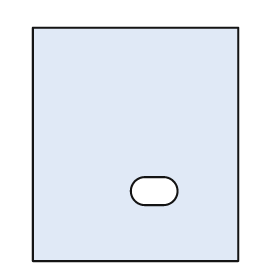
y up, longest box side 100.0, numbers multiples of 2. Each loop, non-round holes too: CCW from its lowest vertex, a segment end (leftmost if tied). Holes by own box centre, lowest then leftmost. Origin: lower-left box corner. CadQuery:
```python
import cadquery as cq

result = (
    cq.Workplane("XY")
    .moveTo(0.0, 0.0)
    .lineTo(88.0, 0.0)
    .lineTo(88.0, 100.0)
    .lineTo(0.0, 100.0)
    .close()
    .moveTo(48.0, 24.0)
    .lineTo(56.0, 24.0)
    .threePointArc((62.0, 30.0), (56.0, 36.0))
    .lineTo(48.0, 36.0)
    .threePointArc((42.0, 30.0), (48.0, 24.0))
    .close()
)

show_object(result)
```